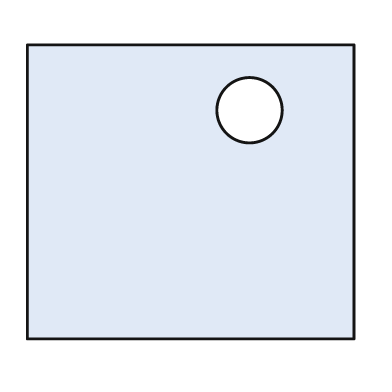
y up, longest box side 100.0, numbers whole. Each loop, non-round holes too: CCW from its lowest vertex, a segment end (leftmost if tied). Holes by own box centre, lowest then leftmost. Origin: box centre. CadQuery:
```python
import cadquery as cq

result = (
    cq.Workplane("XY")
    .moveTo(-50.0, -45.0)
    .lineTo(50.0, -45.0)
    .lineTo(50.0, 45.0)
    .lineTo(-50.0, 45.0)
    .close()
    .moveTo(18.0, 25.0)
    .circle(10.0)
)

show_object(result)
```